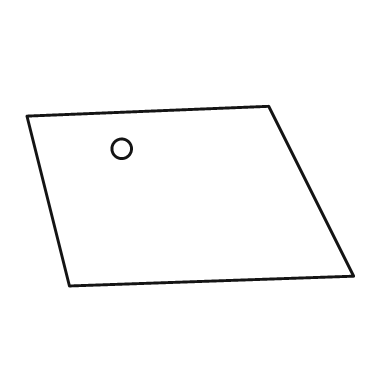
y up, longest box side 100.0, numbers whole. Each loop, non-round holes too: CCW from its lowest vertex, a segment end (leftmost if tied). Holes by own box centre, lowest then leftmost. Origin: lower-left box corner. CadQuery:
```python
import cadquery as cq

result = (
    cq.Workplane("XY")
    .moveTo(13.0, 0.0)
    .lineTo(100.0, 3.0)
    .lineTo(74.0, 55.0)
    .lineTo(0.0, 52.0)
    .close()
    .moveTo(29.0, 42.0)
    .circle(3.0)
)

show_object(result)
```